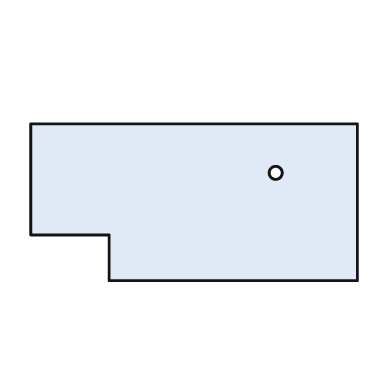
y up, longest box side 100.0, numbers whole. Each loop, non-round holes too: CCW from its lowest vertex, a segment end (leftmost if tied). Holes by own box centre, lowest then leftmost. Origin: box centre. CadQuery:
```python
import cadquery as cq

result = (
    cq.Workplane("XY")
    .moveTo(-26.0, -24.0)
    .lineTo(50.0, -24.0)
    .lineTo(50.0, 24.0)
    .lineTo(-50.0, 24.0)
    .lineTo(-50.0, -10.0)
    .lineTo(-26.0, -10.0)
    .close()
    .moveTo(25.0, 9.0)
    .circle(2.0)
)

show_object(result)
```